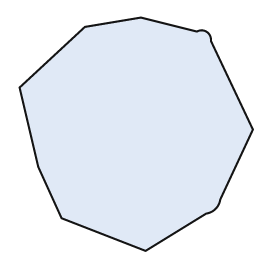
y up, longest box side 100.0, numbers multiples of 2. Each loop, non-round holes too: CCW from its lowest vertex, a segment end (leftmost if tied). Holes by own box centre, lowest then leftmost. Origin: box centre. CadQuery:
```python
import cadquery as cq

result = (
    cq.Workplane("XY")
    .moveTo(4.0, -50.0)
    .lineTo(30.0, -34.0)
    .threePointArc((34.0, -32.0), (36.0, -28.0))
    .lineTo(50.0, 2.0)
    .lineTo(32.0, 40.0)
    .threePointArc((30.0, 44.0), (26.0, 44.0))
    .lineTo(2.0, 50.0)
    .lineTo(-22.0, 46.0)
    .lineTo(-50.0, 20.0)
    .lineTo(-42.0, -14.0)
    .lineTo(-32.0, -36.0)
    .close()
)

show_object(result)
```